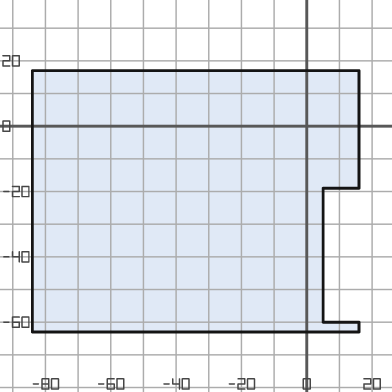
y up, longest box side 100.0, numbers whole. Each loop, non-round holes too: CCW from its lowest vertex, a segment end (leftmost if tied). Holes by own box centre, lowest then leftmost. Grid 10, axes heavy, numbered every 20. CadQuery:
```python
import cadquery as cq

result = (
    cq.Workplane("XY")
    .moveTo(-84.0, -63.0)
    .lineTo(16.0, -63.0)
    .lineTo(16.0, -60.0)
    .lineTo(5.0, -60.0)
    .lineTo(5.0, -19.0)
    .lineTo(16.0, -19.0)
    .lineTo(16.0, 17.0)
    .lineTo(-84.0, 17.0)
    .close()
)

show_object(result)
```